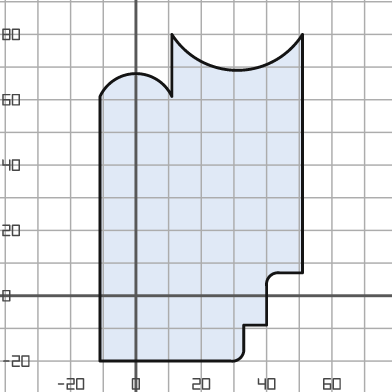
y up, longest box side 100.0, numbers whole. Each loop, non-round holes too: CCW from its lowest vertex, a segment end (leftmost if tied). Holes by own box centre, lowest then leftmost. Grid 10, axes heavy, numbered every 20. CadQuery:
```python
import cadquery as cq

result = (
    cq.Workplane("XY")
    .moveTo(-11.0, -20.0)
    .lineTo(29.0, -20.0)
    .threePointArc((32.0, -19.0), (33.0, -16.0))
    .lineTo(33.0, -9.0)
    .lineTo(40.0, -9.0)
    .lineTo(40.0, 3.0)
    .threePointArc((41.0, 6.0), (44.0, 7.0))
    .lineTo(51.0, 7.0)
    .lineTo(51.0, 80.0)
    .threePointArc((31.0, 69.0), (11.0, 80.0))
    .lineTo(11.0, 61.0)
    .threePointArc((0.0, 68.0), (-11.0, 61.0))
    .close()
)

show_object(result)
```